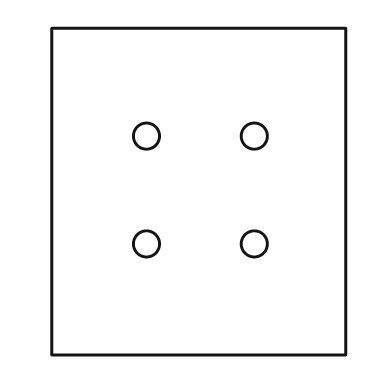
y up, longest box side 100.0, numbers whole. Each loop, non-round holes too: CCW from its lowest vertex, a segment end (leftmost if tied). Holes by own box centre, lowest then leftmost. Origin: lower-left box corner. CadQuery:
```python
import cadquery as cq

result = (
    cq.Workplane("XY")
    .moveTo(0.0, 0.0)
    .lineTo(90.0, 0.0)
    .lineTo(90.0, 100.0)
    .lineTo(0.0, 100.0)
    .close()
    .moveTo(29.0, 34.0)
    .circle(4.0)
    .moveTo(62.0, 34.0)
    .circle(4.0)
    .moveTo(29.0, 67.0)
    .circle(4.0)
    .moveTo(62.0, 67.0)
    .circle(4.0)
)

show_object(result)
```